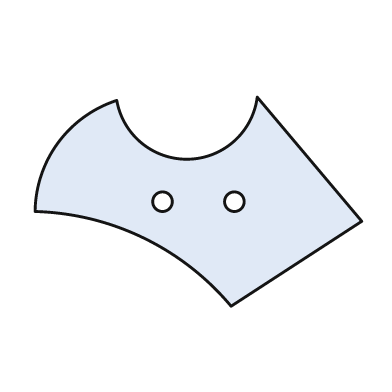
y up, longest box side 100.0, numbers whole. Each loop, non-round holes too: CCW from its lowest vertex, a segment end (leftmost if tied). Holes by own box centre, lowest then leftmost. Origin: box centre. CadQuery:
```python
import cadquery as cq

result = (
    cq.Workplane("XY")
    .moveTo(10.0, -32.0)
    .lineTo(50.0, -6.0)
    .lineTo(18.0, 32.0)
    .threePointArc((-3.0, 13.0), (-25.0, 31.0))
    .threePointArc((-43.0, 18.0), (-50.0, -3.0))
    .threePointArc((-17.0, -11.0), (10.0, -32.0))
    .close()
    .moveTo(-11.0, 0.0)
    .circle(3.0)
    .moveTo(11.0, 0.0)
    .circle(3.0)
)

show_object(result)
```